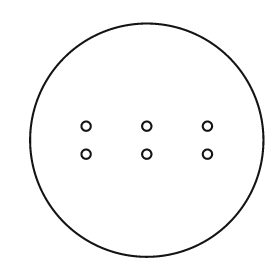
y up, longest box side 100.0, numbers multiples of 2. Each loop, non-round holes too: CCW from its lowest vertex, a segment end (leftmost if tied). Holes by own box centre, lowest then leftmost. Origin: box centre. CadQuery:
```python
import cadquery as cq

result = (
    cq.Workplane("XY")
    .moveTo(0.0, 0.0)
    .circle(50.0)
    .moveTo(-26.0, -6.0)
    .circle(2.0)
    .moveTo(0.0, -6.0)
    .circle(2.0)
    .moveTo(26.0, -6.0)
    .circle(2.0)
    .moveTo(-26.0, 6.0)
    .circle(2.0)
    .moveTo(0.0, 6.0)
    .circle(2.0)
    .moveTo(26.0, 6.0)
    .circle(2.0)
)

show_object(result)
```